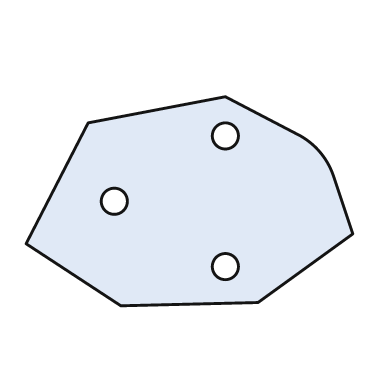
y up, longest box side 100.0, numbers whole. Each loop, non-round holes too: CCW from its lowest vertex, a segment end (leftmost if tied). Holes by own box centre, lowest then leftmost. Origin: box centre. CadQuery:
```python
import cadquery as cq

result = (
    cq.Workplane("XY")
    .moveTo(-21.0, -32.0)
    .lineTo(21.0, -31.0)
    .lineTo(50.0, -10.0)
    .lineTo(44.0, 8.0)
    .threePointArc((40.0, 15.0), (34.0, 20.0))
    .lineTo(11.0, 32.0)
    .lineTo(-31.0, 24.0)
    .lineTo(-50.0, -13.0)
    .close()
    .moveTo(11.0, -20.0)
    .circle(4.0)
    .moveTo(-23.0, 0.0)
    .circle(4.0)
    .moveTo(11.0, 20.0)
    .circle(4.0)
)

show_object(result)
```